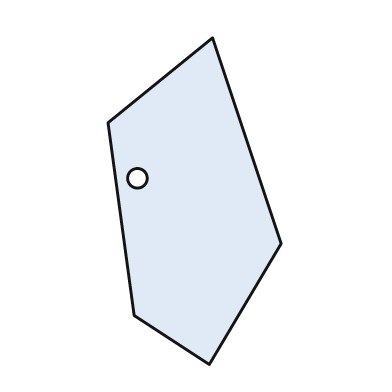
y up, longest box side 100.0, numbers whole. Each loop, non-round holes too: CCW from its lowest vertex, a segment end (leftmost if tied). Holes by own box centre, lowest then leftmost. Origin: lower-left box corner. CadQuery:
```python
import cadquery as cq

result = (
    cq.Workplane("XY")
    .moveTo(31.0, 0.0)
    .lineTo(53.0, 37.0)
    .lineTo(32.0, 100.0)
    .lineTo(0.0, 74.0)
    .lineTo(8.0, 15.0)
    .close()
    .moveTo(9.0, 57.0)
    .circle(3.0)
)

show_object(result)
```